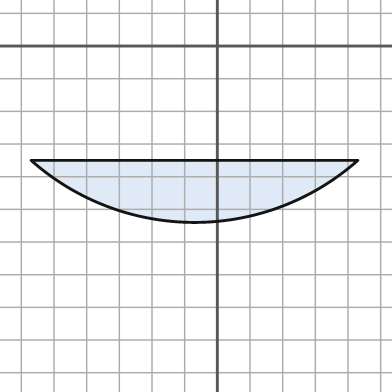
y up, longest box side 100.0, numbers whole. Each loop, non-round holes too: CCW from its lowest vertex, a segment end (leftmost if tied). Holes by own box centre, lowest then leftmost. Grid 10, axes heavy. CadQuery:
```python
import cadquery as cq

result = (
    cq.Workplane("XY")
    .moveTo(-57.0, -35.0)
    .threePointArc((-7.0, -54.0), (43.0, -35.0))
    .close()
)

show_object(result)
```